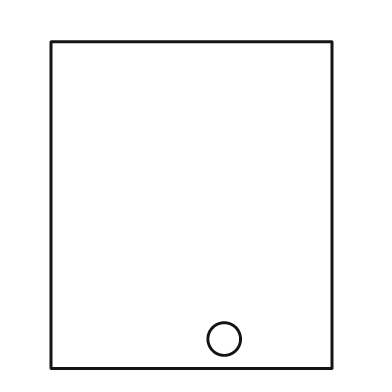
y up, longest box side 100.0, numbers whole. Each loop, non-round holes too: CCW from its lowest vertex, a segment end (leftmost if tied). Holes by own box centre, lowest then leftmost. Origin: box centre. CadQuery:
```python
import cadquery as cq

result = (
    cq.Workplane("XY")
    .moveTo(-43.0, -50.0)
    .lineTo(43.0, -50.0)
    .lineTo(43.0, 50.0)
    .lineTo(-43.0, 50.0)
    .close()
    .moveTo(10.0, -41.0)
    .circle(5.0)
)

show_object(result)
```